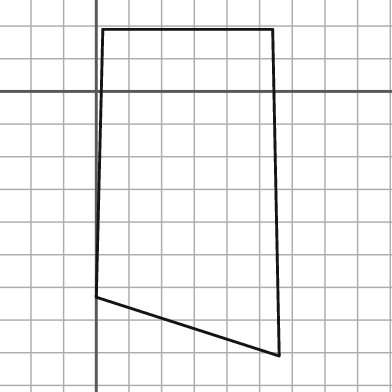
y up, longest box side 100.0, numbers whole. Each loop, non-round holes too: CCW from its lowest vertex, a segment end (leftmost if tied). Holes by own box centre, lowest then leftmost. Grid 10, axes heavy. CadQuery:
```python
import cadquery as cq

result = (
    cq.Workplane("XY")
    .moveTo(56.0, -81.0)
    .lineTo(54.0, 19.0)
    .lineTo(2.0, 19.0)
    .lineTo(0.0, -63.0)
    .close()
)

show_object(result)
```